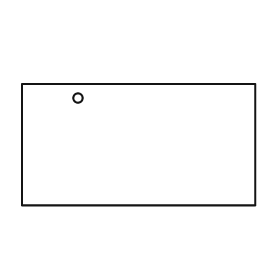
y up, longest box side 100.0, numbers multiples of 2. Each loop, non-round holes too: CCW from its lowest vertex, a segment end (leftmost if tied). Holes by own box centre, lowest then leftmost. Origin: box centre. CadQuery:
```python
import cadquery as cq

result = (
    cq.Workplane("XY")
    .moveTo(-50.0, -26.0)
    .lineTo(50.0, -26.0)
    .lineTo(50.0, 26.0)
    .lineTo(-50.0, 26.0)
    .close()
    .moveTo(-26.0, 20.0)
    .circle(2.0)
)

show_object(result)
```